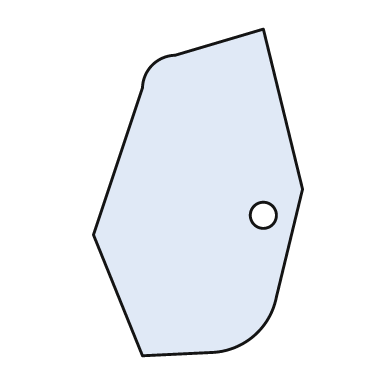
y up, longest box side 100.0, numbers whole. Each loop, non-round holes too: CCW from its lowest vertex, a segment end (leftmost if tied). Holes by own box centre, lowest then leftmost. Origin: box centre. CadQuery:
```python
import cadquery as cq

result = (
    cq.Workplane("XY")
    .moveTo(-17.0, -50.0)
    .lineTo(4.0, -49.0)
    .threePointArc((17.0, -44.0), (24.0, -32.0))
    .lineTo(32.0, 1.0)
    .lineTo(20.0, 50.0)
    .lineTo(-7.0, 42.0)
    .threePointArc((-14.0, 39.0), (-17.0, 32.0))
    .lineTo(-32.0, -13.0)
    .close()
    .moveTo(20.0, -7.0)
    .circle(4.0)
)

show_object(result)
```